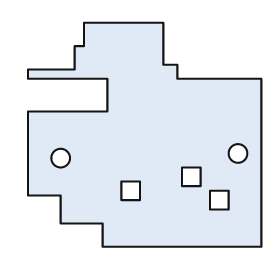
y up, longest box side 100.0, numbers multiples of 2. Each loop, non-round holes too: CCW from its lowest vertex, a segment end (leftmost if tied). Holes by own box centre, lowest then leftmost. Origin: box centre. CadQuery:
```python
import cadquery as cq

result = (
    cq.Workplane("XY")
    .moveTo(-18.0, -48.0)
    .lineTo(50.0, -48.0)
    .lineTo(50.0, 24.0)
    .lineTo(14.0, 24.0)
    .lineTo(14.0, 30.0)
    .lineTo(8.0, 30.0)
    .lineTo(8.0, 48.0)
    .lineTo(-26.0, 48.0)
    .lineTo(-26.0, 38.0)
    .lineTo(-30.0, 38.0)
    .lineTo(-30.0, 28.0)
    .lineTo(-50.0, 28.0)
    .lineTo(-50.0, 24.0)
    .lineTo(-16.0, 24.0)
    .lineTo(-16.0, 10.0)
    .lineTo(-50.0, 10.0)
    .lineTo(-50.0, -26.0)
    .lineTo(-36.0, -26.0)
    .lineTo(-36.0, -38.0)
    .lineTo(-18.0, -38.0)
    .close()
    .moveTo(28.0, -32.0)
    .lineTo(36.0, -32.0)
    .lineTo(36.0, -24.0)
    .lineTo(28.0, -24.0)
    .close()
    .moveTo(-10.0, -28.0)
    .lineTo(-2.0, -28.0)
    .lineTo(-2.0, -20.0)
    .lineTo(-10.0, -20.0)
    .close()
    .moveTo(16.0, -22.0)
    .lineTo(24.0, -22.0)
    .lineTo(24.0, -14.0)
    .lineTo(16.0, -14.0)
    .close()
    .moveTo(-36.0, -10.0)
    .circle(4.0)
    .moveTo(40.0, -8.0)
    .circle(4.0)
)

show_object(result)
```